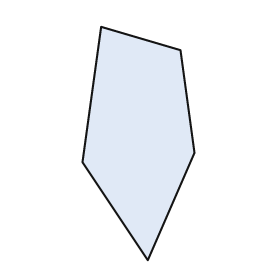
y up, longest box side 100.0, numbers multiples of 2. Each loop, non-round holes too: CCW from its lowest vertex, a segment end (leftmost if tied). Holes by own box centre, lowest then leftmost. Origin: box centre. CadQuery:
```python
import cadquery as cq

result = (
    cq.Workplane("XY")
    .moveTo(4.0, -50.0)
    .lineTo(24.0, -4.0)
    .lineTo(18.0, 40.0)
    .lineTo(-16.0, 50.0)
    .lineTo(-24.0, -8.0)
    .close()
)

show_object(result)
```